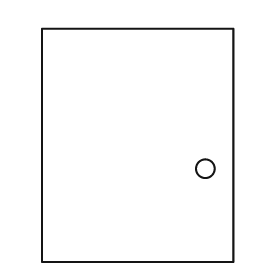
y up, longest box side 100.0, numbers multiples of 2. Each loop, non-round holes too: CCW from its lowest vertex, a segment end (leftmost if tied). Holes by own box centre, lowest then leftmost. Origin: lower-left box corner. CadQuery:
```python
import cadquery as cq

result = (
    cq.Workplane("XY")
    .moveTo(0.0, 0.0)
    .lineTo(82.0, 0.0)
    .lineTo(82.0, 100.0)
    .lineTo(0.0, 100.0)
    .close()
    .moveTo(70.0, 40.0)
    .circle(4.0)
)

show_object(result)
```